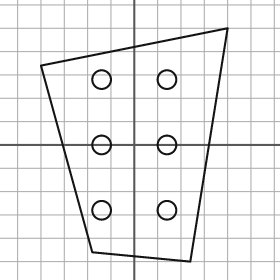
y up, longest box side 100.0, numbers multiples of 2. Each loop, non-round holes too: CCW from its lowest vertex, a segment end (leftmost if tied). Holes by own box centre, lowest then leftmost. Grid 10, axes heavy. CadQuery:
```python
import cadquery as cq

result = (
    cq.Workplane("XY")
    .moveTo(24.0, -50.0)
    .lineTo(40.0, 50.0)
    .lineTo(-40.0, 34.0)
    .lineTo(-18.0, -46.0)
    .close()
    .moveTo(-14.0, -28.0)
    .circle(4.0)
    .moveTo(14.0, -28.0)
    .circle(4.0)
    .moveTo(-14.0, 0.0)
    .circle(4.0)
    .moveTo(14.0, 0.0)
    .circle(4.0)
    .moveTo(-14.0, 28.0)
    .circle(4.0)
    .moveTo(14.0, 28.0)
    .circle(4.0)
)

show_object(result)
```